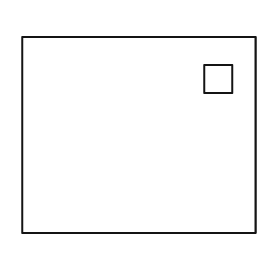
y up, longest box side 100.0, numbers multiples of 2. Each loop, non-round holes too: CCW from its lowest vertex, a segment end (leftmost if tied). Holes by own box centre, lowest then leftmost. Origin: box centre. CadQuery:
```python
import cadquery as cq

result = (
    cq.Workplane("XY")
    .moveTo(-50.0, -42.0)
    .lineTo(50.0, -42.0)
    .lineTo(50.0, 42.0)
    .lineTo(-50.0, 42.0)
    .close()
    .moveTo(28.0, 18.0)
    .lineTo(40.0, 18.0)
    .lineTo(40.0, 30.0)
    .lineTo(28.0, 30.0)
    .close()
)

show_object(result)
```